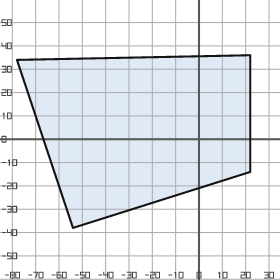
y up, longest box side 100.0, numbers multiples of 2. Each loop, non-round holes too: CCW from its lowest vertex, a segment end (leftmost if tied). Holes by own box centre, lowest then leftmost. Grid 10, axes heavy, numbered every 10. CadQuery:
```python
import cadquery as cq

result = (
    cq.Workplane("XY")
    .moveTo(-54.0, -38.0)
    .lineTo(22.0, -14.0)
    .lineTo(22.0, 36.0)
    .lineTo(-78.0, 34.0)
    .close()
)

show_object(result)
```